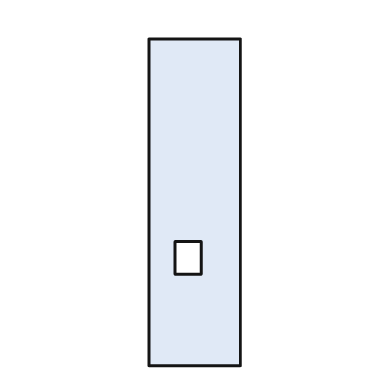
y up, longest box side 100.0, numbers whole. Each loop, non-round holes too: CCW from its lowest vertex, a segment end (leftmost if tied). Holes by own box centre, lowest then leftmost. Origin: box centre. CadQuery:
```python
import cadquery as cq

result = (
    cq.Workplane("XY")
    .moveTo(-14.0, -50.0)
    .lineTo(14.0, -50.0)
    .lineTo(14.0, 50.0)
    .lineTo(-14.0, 50.0)
    .close()
    .moveTo(-6.0, -22.0)
    .lineTo(2.0, -22.0)
    .lineTo(2.0, -12.0)
    .lineTo(-6.0, -12.0)
    .close()
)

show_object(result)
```